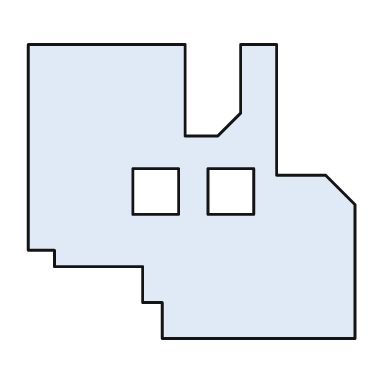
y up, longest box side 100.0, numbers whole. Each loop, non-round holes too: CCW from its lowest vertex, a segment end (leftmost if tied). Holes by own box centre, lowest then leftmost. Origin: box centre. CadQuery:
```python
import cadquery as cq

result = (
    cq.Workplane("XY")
    .moveTo(-9.0, -45.0)
    .lineTo(50.0, -45.0)
    .lineTo(50.0, -4.0)
    .lineTo(41.0, 5.0)
    .lineTo(26.0, 5.0)
    .lineTo(26.0, 45.0)
    .lineTo(15.0, 45.0)
    .lineTo(15.0, 24.0)
    .lineTo(8.0, 17.0)
    .lineTo(-2.0, 17.0)
    .lineTo(-2.0, 45.0)
    .lineTo(-50.0, 45.0)
    .lineTo(-50.0, -18.0)
    .lineTo(-42.0, -18.0)
    .lineTo(-42.0, -23.0)
    .lineTo(-15.0, -23.0)
    .lineTo(-15.0, -34.0)
    .lineTo(-9.0, -34.0)
    .close()
    .moveTo(-18.0, -7.0)
    .lineTo(-4.0, -7.0)
    .lineTo(-4.0, 7.0)
    .lineTo(-18.0, 7.0)
    .close()
    .moveTo(5.0, -7.0)
    .lineTo(19.0, -7.0)
    .lineTo(19.0, 7.0)
    .lineTo(5.0, 7.0)
    .close()
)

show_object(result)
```